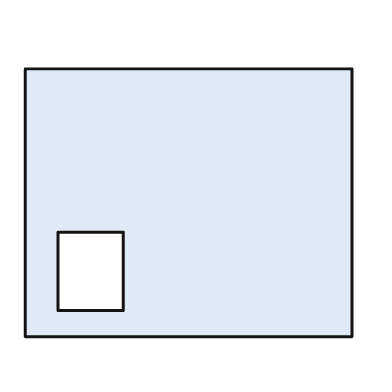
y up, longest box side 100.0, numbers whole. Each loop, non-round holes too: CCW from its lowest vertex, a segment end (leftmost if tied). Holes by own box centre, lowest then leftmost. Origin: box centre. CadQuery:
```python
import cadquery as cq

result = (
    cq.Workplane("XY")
    .moveTo(-50.0, -41.0)
    .lineTo(50.0, -41.0)
    .lineTo(50.0, 41.0)
    .lineTo(-50.0, 41.0)
    .close()
    .moveTo(-40.0, -33.0)
    .lineTo(-20.0, -33.0)
    .lineTo(-20.0, -9.0)
    .lineTo(-40.0, -9.0)
    .close()
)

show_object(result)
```